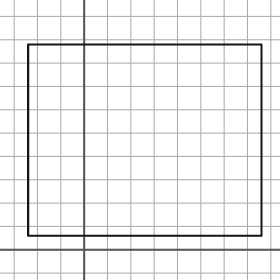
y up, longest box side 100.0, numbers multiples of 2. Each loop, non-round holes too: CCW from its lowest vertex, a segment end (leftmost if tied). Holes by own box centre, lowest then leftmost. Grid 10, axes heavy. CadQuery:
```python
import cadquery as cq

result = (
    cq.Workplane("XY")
    .moveTo(-24.0, 6.0)
    .lineTo(76.0, 6.0)
    .lineTo(76.0, 88.0)
    .lineTo(-24.0, 88.0)
    .close()
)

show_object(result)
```